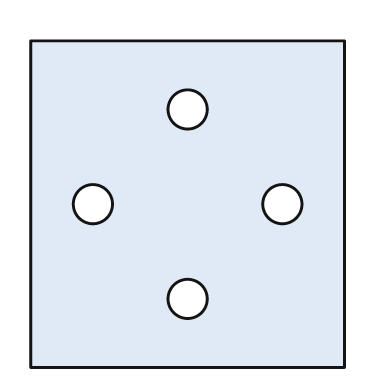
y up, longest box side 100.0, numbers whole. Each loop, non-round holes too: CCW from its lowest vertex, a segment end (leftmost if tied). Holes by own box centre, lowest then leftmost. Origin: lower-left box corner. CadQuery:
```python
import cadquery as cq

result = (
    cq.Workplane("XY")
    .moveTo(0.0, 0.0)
    .lineTo(96.0, 0.0)
    .lineTo(96.0, 100.0)
    .lineTo(0.0, 100.0)
    .close()
    .moveTo(48.0, 21.0)
    .circle(6.0)
    .moveTo(19.0, 50.0)
    .circle(6.0)
    .moveTo(77.0, 50.0)
    .circle(6.0)
    .moveTo(48.0, 79.0)
    .circle(6.0)
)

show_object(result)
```